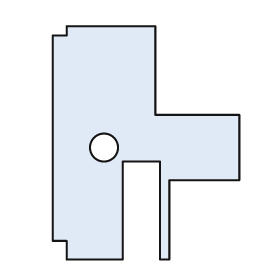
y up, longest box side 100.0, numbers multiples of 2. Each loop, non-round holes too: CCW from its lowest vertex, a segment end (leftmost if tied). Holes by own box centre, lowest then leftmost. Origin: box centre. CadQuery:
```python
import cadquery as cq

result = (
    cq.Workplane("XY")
    .moveTo(-34.0, -50.0)
    .lineTo(-10.0, -50.0)
    .lineTo(-10.0, -8.0)
    .lineTo(6.0, -8.0)
    .lineTo(6.0, -50.0)
    .lineTo(10.0, -50.0)
    .lineTo(10.0, -16.0)
    .lineTo(40.0, -16.0)
    .lineTo(40.0, 12.0)
    .lineTo(4.0, 12.0)
    .lineTo(4.0, 50.0)
    .lineTo(-34.0, 50.0)
    .lineTo(-34.0, 46.0)
    .lineTo(-40.0, 46.0)
    .lineTo(-40.0, -42.0)
    .lineTo(-34.0, -42.0)
    .close()
    .moveTo(-18.0, -2.0)
    .circle(6.0)
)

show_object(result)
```